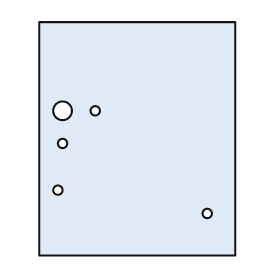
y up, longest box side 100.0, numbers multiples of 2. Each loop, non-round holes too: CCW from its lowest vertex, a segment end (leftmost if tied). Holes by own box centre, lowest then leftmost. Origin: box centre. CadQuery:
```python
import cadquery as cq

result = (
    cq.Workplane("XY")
    .moveTo(-42.0, -50.0)
    .lineTo(42.0, -50.0)
    .lineTo(42.0, 50.0)
    .lineTo(-42.0, 50.0)
    .close()
    .moveTo(30.0, -32.0)
    .circle(2.0)
    .moveTo(-34.0, -22.0)
    .circle(2.0)
    .moveTo(-32.0, -2.0)
    .circle(2.0)
    .moveTo(-32.0, 12.0)
    .circle(4.0)
    .moveTo(-18.0, 12.0)
    .circle(2.0)
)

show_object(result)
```